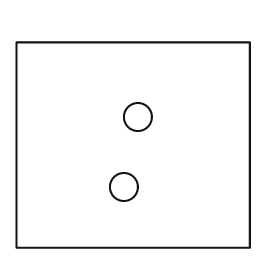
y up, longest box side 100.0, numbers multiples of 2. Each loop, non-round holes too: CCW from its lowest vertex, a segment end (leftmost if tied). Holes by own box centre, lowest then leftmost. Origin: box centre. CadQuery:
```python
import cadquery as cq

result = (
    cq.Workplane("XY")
    .moveTo(-50.0, -44.0)
    .lineTo(50.0, -44.0)
    .lineTo(50.0, 44.0)
    .lineTo(-50.0, 44.0)
    .close()
    .moveTo(-4.0, -18.0)
    .circle(6.0)
    .moveTo(2.0, 12.0)
    .circle(6.0)
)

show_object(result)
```